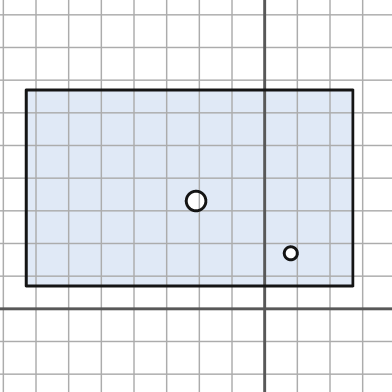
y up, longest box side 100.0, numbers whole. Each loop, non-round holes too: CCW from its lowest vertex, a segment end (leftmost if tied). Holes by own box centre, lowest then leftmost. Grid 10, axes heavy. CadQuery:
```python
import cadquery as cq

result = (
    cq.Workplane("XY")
    .moveTo(-73.0, 7.0)
    .lineTo(27.0, 7.0)
    .lineTo(27.0, 67.0)
    .lineTo(-73.0, 67.0)
    .close()
    .moveTo(8.0, 17.0)
    .circle(2.0)
    .moveTo(-21.0, 33.0)
    .circle(3.0)
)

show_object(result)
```